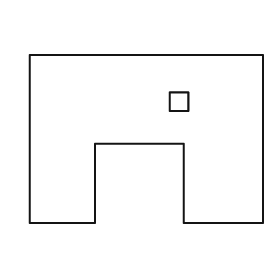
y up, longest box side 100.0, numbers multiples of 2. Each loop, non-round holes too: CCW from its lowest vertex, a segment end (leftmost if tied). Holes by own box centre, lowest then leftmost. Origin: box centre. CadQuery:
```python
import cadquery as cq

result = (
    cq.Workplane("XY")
    .moveTo(-50.0, -36.0)
    .lineTo(-22.0, -36.0)
    .lineTo(-22.0, -2.0)
    .lineTo(16.0, -2.0)
    .lineTo(16.0, -36.0)
    .lineTo(50.0, -36.0)
    .lineTo(50.0, 36.0)
    .lineTo(-50.0, 36.0)
    .close()
    .moveTo(10.0, 12.0)
    .lineTo(18.0, 12.0)
    .lineTo(18.0, 20.0)
    .lineTo(10.0, 20.0)
    .close()
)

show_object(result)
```